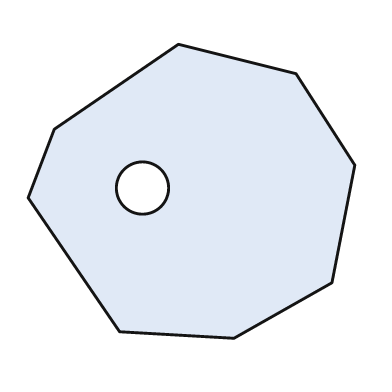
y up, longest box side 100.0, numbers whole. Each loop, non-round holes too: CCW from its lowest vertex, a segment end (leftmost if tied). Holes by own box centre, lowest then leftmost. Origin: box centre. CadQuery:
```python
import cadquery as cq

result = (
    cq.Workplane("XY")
    .moveTo(13.0, -45.0)
    .lineTo(43.0, -28.0)
    .lineTo(50.0, 8.0)
    .lineTo(32.0, 36.0)
    .lineTo(-4.0, 45.0)
    .lineTo(-42.0, 19.0)
    .lineTo(-50.0, -2.0)
    .lineTo(-22.0, -43.0)
    .close()
    .moveTo(-15.0, 1.0)
    .circle(8.0)
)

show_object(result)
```